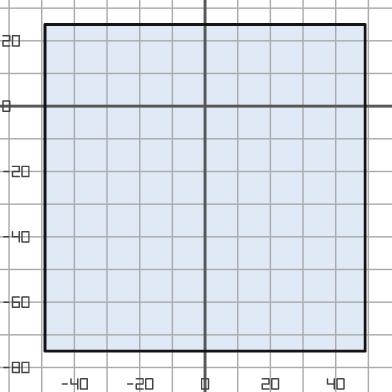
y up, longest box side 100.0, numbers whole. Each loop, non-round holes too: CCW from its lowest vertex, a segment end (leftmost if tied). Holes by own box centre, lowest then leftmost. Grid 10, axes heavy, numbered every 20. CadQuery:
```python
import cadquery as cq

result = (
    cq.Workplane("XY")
    .moveTo(-49.0, -75.0)
    .lineTo(49.0, -75.0)
    .lineTo(49.0, 25.0)
    .lineTo(-49.0, 25.0)
    .close()
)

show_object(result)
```